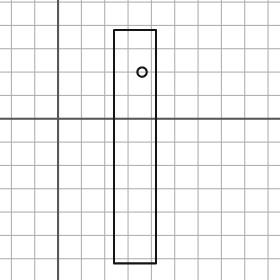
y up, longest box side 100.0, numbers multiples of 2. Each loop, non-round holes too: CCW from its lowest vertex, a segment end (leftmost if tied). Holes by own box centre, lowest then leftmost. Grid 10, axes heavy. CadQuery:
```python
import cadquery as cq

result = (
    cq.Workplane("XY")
    .moveTo(24.0, -62.0)
    .lineTo(42.0, -62.0)
    .lineTo(42.0, 38.0)
    .lineTo(24.0, 38.0)
    .close()
    .moveTo(36.0, 20.0)
    .circle(2.0)
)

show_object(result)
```